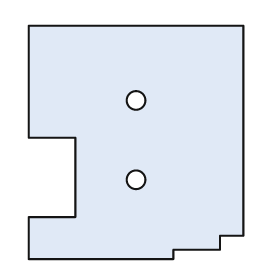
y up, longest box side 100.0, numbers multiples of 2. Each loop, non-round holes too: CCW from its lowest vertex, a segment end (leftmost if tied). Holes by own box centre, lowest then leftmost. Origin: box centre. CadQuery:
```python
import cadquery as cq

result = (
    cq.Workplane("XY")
    .moveTo(-46.0, -50.0)
    .lineTo(16.0, -50.0)
    .lineTo(16.0, -46.0)
    .lineTo(36.0, -46.0)
    .lineTo(36.0, -40.0)
    .lineTo(46.0, -40.0)
    .lineTo(46.0, 50.0)
    .lineTo(-46.0, 50.0)
    .lineTo(-46.0, 2.0)
    .lineTo(-26.0, 2.0)
    .lineTo(-26.0, -32.0)
    .lineTo(-46.0, -32.0)
    .close()
    .moveTo(0.0, -16.0)
    .circle(4.0)
    .moveTo(0.0, 18.0)
    .circle(4.0)
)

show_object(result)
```